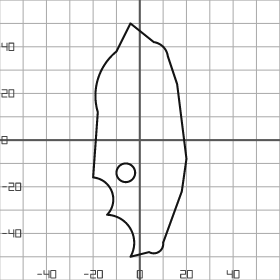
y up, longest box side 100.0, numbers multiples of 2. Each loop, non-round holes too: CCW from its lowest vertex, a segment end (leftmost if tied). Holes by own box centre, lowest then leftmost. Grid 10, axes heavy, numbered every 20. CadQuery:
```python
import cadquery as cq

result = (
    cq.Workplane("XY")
    .moveTo(-4.0, -50.0)
    .lineTo(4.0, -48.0)
    .threePointArc((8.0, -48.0), (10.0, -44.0))
    .lineTo(18.0, -22.0)
    .lineTo(20.0, -8.0)
    .lineTo(16.0, 24.0)
    .lineTo(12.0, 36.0)
    .threePointArc((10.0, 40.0), (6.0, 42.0))
    .lineTo(-4.0, 50.0)
    .lineTo(-10.0, 38.0)
    .threePointArc((-18.0, 26.0), (-18.0, 12.0))
    .lineTo(-20.0, -16.0)
    .threePointArc((-12.0, -22.0), (-14.0, -32.0))
    .threePointArc((-4.0, -38.0), (-4.0, -50.0))
    .close()
    .moveTo(-6.0, -14.0)
    .circle(4.0)
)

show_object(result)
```